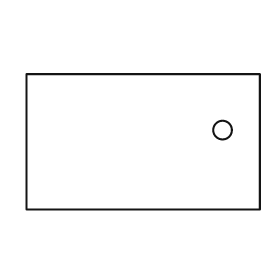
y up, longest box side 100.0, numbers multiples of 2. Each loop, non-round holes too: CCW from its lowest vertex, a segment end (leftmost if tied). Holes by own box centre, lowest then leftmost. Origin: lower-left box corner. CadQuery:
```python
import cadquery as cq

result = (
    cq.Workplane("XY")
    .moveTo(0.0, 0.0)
    .lineTo(100.0, 0.0)
    .lineTo(100.0, 58.0)
    .lineTo(0.0, 58.0)
    .close()
    .moveTo(84.0, 34.0)
    .circle(4.0)
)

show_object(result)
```